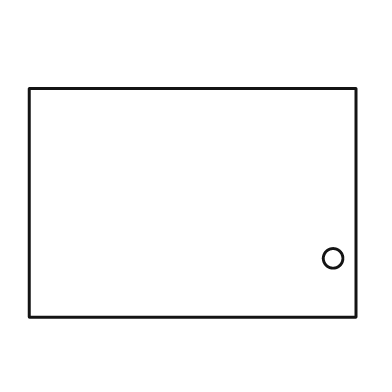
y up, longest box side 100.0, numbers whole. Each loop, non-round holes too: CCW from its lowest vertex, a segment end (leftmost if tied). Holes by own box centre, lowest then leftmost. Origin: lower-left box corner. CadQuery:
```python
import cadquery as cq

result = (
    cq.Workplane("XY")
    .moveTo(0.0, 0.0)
    .lineTo(100.0, 0.0)
    .lineTo(100.0, 70.0)
    .lineTo(0.0, 70.0)
    .close()
    .moveTo(93.0, 18.0)
    .circle(3.0)
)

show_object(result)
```